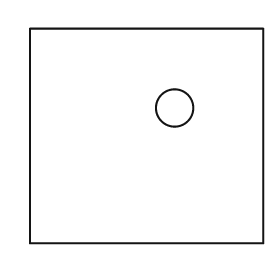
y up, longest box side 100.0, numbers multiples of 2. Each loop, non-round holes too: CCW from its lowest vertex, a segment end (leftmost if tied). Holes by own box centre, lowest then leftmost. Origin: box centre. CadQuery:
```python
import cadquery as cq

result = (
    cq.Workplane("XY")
    .moveTo(-50.0, -46.0)
    .lineTo(50.0, -46.0)
    .lineTo(50.0, 46.0)
    .lineTo(-50.0, 46.0)
    .close()
    .moveTo(12.0, 12.0)
    .circle(8.0)
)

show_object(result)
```